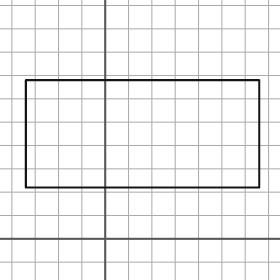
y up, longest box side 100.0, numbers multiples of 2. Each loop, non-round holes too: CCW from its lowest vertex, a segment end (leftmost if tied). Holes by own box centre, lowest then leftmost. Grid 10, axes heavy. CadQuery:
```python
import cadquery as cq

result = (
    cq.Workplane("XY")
    .moveTo(-34.0, 22.0)
    .lineTo(66.0, 22.0)
    .lineTo(66.0, 68.0)
    .lineTo(-34.0, 68.0)
    .close()
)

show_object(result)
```